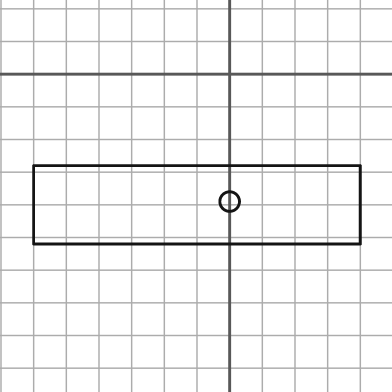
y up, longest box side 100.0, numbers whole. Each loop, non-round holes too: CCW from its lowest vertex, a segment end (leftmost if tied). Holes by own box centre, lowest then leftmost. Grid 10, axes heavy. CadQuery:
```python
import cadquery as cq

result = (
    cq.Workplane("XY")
    .moveTo(-60.0, -52.0)
    .lineTo(40.0, -52.0)
    .lineTo(40.0, -28.0)
    .lineTo(-60.0, -28.0)
    .close()
    .moveTo(0.0, -39.0)
    .circle(3.0)
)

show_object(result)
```